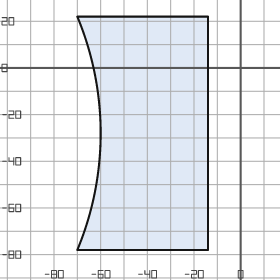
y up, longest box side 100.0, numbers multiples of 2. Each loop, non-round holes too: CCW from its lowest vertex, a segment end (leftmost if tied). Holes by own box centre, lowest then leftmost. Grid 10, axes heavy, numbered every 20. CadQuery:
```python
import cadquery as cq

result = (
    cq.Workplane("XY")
    .moveTo(-70.0, -78.0)
    .lineTo(-14.0, -78.0)
    .lineTo(-14.0, 22.0)
    .lineTo(-70.0, 22.0)
    .threePointArc((-60.0, -28.0), (-70.0, -78.0))
    .close()
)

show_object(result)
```